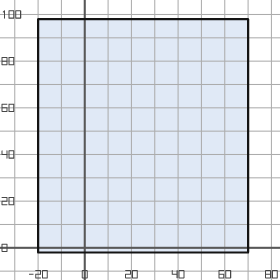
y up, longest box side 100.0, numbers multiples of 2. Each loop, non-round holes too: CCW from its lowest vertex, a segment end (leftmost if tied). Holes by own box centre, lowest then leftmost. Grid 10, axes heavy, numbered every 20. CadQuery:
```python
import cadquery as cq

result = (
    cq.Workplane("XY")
    .moveTo(-20.0, -2.0)
    .lineTo(70.0, -2.0)
    .lineTo(70.0, 98.0)
    .lineTo(-20.0, 98.0)
    .close()
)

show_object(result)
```